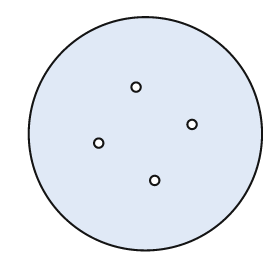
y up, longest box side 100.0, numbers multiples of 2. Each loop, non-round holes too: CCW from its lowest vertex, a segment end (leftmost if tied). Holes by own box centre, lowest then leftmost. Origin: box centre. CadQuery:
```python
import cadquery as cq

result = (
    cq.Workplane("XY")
    .moveTo(0.0, 0.0)
    .circle(50.0)
    .moveTo(4.0, -20.0)
    .circle(2.0)
    .moveTo(-20.0, -4.0)
    .circle(2.0)
    .moveTo(20.0, 4.0)
    .circle(2.0)
    .moveTo(-4.0, 20.0)
    .circle(2.0)
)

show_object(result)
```